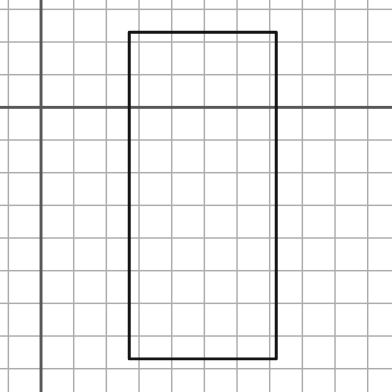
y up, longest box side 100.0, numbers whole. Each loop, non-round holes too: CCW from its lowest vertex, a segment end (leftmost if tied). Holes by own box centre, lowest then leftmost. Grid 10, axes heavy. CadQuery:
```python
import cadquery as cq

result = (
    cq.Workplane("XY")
    .moveTo(27.0, -77.0)
    .lineTo(72.0, -77.0)
    .lineTo(72.0, 23.0)
    .lineTo(27.0, 23.0)
    .close()
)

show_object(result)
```